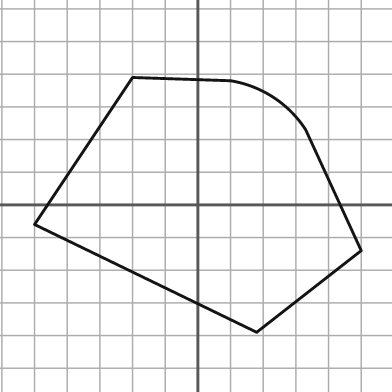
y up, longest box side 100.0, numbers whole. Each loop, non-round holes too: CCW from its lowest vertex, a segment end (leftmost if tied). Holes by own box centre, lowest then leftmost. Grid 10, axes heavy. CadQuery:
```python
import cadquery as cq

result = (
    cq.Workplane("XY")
    .moveTo(18.0, -39.0)
    .lineTo(50.0, -14.0)
    .lineTo(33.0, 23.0)
    .threePointArc((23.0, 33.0), (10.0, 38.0))
    .lineTo(-20.0, 39.0)
    .lineTo(-50.0, -6.0)
    .close()
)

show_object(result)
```